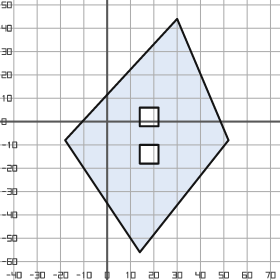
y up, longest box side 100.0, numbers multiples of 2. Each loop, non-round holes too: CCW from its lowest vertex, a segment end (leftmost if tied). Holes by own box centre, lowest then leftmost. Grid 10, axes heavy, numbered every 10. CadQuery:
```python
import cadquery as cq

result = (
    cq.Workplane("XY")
    .moveTo(14.0, -56.0)
    .lineTo(52.0, -8.0)
    .lineTo(30.0, 44.0)
    .lineTo(-18.0, -8.0)
    .close()
    .moveTo(14.0, -18.0)
    .lineTo(22.0, -18.0)
    .lineTo(22.0, -10.0)
    .lineTo(14.0, -10.0)
    .close()
    .moveTo(14.0, -2.0)
    .lineTo(22.0, -2.0)
    .lineTo(22.0, 6.0)
    .lineTo(14.0, 6.0)
    .close()
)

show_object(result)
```